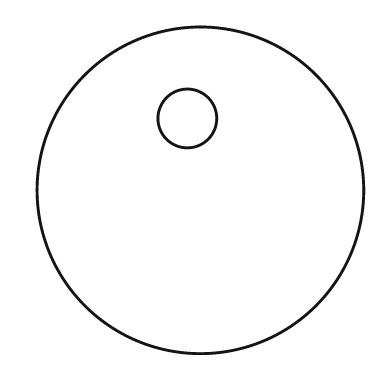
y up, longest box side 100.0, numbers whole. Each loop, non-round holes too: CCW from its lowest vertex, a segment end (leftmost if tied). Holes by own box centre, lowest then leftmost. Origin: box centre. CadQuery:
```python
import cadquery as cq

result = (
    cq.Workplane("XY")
    .moveTo(0.0, 0.0)
    .circle(50.0)
    .moveTo(-4.0, 22.0)
    .circle(9.0)
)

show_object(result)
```